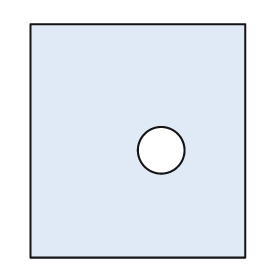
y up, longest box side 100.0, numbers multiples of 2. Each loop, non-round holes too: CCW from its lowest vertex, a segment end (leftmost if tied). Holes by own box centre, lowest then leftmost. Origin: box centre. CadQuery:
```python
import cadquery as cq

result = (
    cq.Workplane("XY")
    .moveTo(-46.0, -50.0)
    .lineTo(46.0, -50.0)
    .lineTo(46.0, 50.0)
    .lineTo(-46.0, 50.0)
    .close()
    .moveTo(10.0, -4.0)
    .circle(10.0)
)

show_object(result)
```